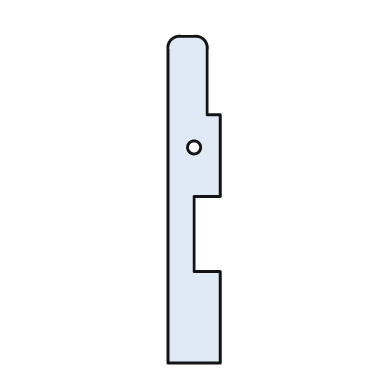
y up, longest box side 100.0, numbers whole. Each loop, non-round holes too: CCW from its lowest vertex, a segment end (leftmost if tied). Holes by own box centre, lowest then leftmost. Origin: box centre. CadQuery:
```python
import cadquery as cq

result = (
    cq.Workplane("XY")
    .moveTo(-8.0, -50.0)
    .lineTo(8.0, -50.0)
    .lineTo(8.0, -22.0)
    .lineTo(0.0, -22.0)
    .lineTo(0.0, 1.0)
    .lineTo(8.0, 1.0)
    .lineTo(8.0, 26.0)
    .lineTo(4.0, 26.0)
    .lineTo(4.0, 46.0)
    .threePointArc((3.0, 49.0), (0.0, 50.0))
    .lineTo(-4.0, 50.0)
    .threePointArc((-7.0, 49.0), (-8.0, 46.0))
    .close()
    .moveTo(0.0, 16.0)
    .circle(2.0)
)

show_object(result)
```